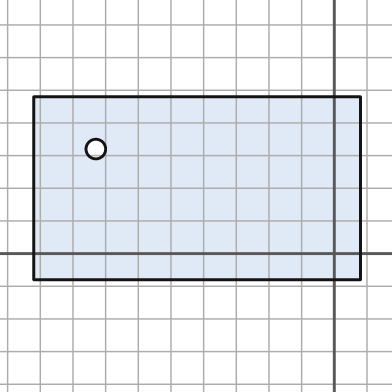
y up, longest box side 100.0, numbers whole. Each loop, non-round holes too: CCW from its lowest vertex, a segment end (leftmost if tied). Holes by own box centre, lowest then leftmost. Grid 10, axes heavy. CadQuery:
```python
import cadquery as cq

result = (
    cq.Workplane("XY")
    .moveTo(-92.0, -8.0)
    .lineTo(8.0, -8.0)
    .lineTo(8.0, 48.0)
    .lineTo(-92.0, 48.0)
    .close()
    .moveTo(-73.0, 32.0)
    .circle(3.0)
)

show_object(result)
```